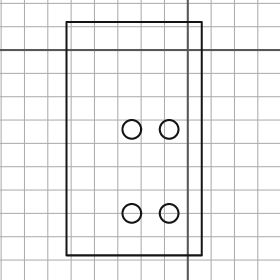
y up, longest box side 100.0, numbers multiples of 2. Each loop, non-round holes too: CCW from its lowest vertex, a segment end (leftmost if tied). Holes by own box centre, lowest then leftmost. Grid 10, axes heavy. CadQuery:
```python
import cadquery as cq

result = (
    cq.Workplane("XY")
    .moveTo(-52.0, -88.0)
    .lineTo(6.0, -88.0)
    .lineTo(6.0, 12.0)
    .lineTo(-52.0, 12.0)
    .close()
    .moveTo(-24.0, -70.0)
    .circle(4.0)
    .moveTo(-8.0, -70.0)
    .circle(4.0)
    .moveTo(-24.0, -34.0)
    .circle(4.0)
    .moveTo(-8.0, -34.0)
    .circle(4.0)
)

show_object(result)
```